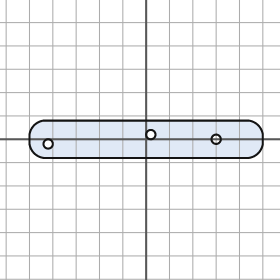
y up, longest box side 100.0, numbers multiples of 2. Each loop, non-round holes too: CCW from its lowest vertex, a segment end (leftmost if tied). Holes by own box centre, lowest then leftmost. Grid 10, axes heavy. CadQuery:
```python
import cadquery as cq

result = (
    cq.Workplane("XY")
    .moveTo(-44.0, -8.0)
    .lineTo(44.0, -8.0)
    .threePointArc((48.0, -6.0), (50.0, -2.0))
    .lineTo(50.0, 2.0)
    .threePointArc((48.0, 6.0), (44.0, 8.0))
    .lineTo(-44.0, 8.0)
    .threePointArc((-48.0, 6.0), (-50.0, 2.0))
    .lineTo(-50.0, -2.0)
    .threePointArc((-48.0, -6.0), (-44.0, -8.0))
    .close()
    .moveTo(-42.0, -2.0)
    .circle(2.0)
    .moveTo(30.0, 0.0)
    .circle(2.0)
    .moveTo(2.0, 2.0)
    .circle(2.0)
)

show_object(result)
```